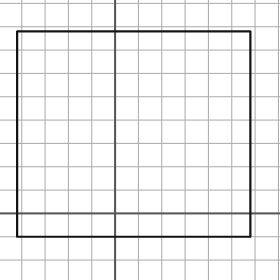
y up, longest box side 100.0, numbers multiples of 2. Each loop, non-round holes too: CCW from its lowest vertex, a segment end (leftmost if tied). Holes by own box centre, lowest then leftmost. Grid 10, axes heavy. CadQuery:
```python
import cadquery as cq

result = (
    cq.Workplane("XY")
    .moveTo(-42.0, -10.0)
    .lineTo(58.0, -10.0)
    .lineTo(58.0, 78.0)
    .lineTo(-42.0, 78.0)
    .close()
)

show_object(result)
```